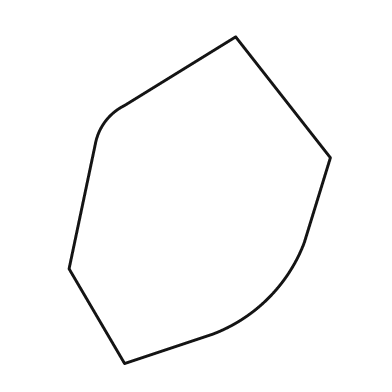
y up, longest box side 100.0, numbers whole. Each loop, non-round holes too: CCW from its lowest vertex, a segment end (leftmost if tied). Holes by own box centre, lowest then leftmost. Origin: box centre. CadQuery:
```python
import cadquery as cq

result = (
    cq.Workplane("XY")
    .moveTo(-23.0, -50.0)
    .lineTo(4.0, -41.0)
    .threePointArc((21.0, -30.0), (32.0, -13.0))
    .lineTo(40.0, 13.0)
    .lineTo(11.0, 50.0)
    .lineTo(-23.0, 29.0)
    .threePointArc((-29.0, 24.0), (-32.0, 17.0))
    .lineTo(-40.0, -21.0)
    .close()
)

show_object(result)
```